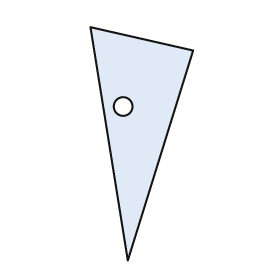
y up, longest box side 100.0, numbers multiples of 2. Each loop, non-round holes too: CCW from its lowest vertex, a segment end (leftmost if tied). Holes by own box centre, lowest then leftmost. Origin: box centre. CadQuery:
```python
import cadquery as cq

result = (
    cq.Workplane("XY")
    .moveTo(-6.0, -50.0)
    .lineTo(22.0, 40.0)
    .lineTo(-22.0, 50.0)
    .close()
    .moveTo(-8.0, 16.0)
    .circle(4.0)
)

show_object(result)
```